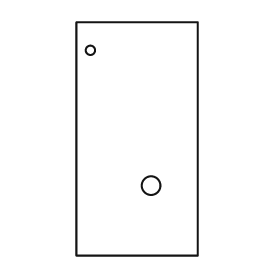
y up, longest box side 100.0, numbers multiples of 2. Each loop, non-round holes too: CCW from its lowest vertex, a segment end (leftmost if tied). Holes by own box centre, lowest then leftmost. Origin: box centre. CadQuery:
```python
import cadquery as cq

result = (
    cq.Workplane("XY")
    .moveTo(-26.0, -50.0)
    .lineTo(26.0, -50.0)
    .lineTo(26.0, 50.0)
    .lineTo(-26.0, 50.0)
    .close()
    .moveTo(6.0, -20.0)
    .circle(4.0)
    .moveTo(-20.0, 38.0)
    .circle(2.0)
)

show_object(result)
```